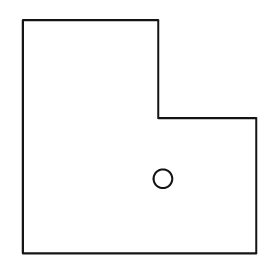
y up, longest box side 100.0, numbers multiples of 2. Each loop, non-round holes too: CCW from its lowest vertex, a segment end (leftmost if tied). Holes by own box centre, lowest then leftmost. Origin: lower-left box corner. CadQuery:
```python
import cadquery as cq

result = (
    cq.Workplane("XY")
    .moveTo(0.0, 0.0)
    .lineTo(100.0, 0.0)
    .lineTo(100.0, 58.0)
    .lineTo(58.0, 58.0)
    .lineTo(58.0, 100.0)
    .lineTo(0.0, 100.0)
    .close()
    .moveTo(60.0, 32.0)
    .circle(4.0)
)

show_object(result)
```